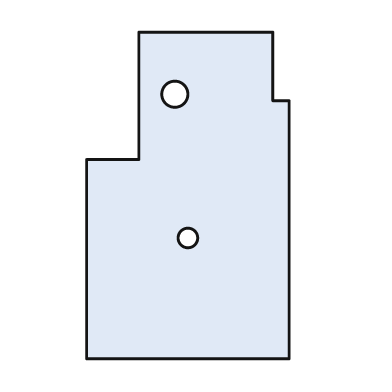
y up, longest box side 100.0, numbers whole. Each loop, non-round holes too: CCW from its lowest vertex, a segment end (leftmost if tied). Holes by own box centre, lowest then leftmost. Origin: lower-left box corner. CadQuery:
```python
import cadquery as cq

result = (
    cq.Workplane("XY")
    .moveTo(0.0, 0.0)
    .lineTo(62.0, 0.0)
    .lineTo(62.0, 79.0)
    .lineTo(57.0, 79.0)
    .lineTo(57.0, 100.0)
    .lineTo(16.0, 100.0)
    .lineTo(16.0, 61.0)
    .lineTo(0.0, 61.0)
    .close()
    .moveTo(31.0, 37.0)
    .circle(3.0)
    .moveTo(27.0, 81.0)
    .circle(4.0)
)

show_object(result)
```